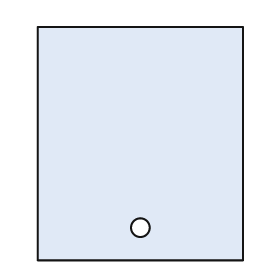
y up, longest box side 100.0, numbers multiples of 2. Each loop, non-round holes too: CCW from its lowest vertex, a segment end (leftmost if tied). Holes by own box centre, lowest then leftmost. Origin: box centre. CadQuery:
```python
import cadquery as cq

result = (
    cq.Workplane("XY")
    .moveTo(-44.0, -50.0)
    .lineTo(44.0, -50.0)
    .lineTo(44.0, 50.0)
    .lineTo(-44.0, 50.0)
    .close()
    .moveTo(0.0, -36.0)
    .circle(4.0)
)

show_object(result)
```